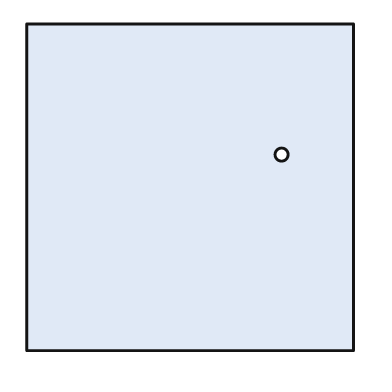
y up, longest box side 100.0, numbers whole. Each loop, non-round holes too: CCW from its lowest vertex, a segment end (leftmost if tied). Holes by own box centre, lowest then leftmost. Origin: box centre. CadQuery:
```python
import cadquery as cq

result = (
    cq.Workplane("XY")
    .moveTo(-50.0, -50.0)
    .lineTo(50.0, -50.0)
    .lineTo(50.0, 50.0)
    .lineTo(-50.0, 50.0)
    .close()
    .moveTo(28.0, 10.0)
    .circle(2.0)
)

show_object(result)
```